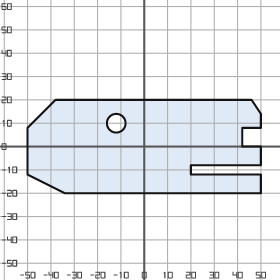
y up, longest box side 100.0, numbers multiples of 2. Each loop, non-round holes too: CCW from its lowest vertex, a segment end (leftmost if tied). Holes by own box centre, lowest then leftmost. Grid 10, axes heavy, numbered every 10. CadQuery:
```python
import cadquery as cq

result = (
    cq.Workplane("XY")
    .moveTo(-34.0, -20.0)
    .lineTo(50.0, -20.0)
    .lineTo(50.0, -12.0)
    .lineTo(20.0, -12.0)
    .lineTo(20.0, -8.0)
    .lineTo(50.0, -8.0)
    .lineTo(50.0, 0.0)
    .lineTo(42.0, 0.0)
    .lineTo(42.0, 8.0)
    .lineTo(50.0, 8.0)
    .lineTo(50.0, 14.0)
    .lineTo(46.0, 20.0)
    .lineTo(-38.0, 20.0)
    .lineTo(-50.0, 8.0)
    .lineTo(-50.0, -12.0)
    .close()
    .moveTo(-12.0, 10.0)
    .circle(4.0)
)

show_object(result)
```